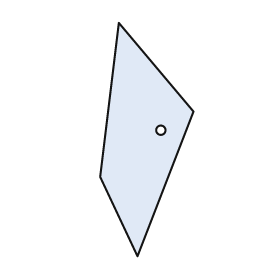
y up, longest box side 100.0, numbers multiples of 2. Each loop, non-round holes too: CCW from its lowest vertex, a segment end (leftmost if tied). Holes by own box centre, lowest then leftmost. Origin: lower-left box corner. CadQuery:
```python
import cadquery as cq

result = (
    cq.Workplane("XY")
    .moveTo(16.0, 0.0)
    .lineTo(40.0, 62.0)
    .lineTo(8.0, 100.0)
    .lineTo(0.0, 34.0)
    .close()
    .moveTo(26.0, 54.0)
    .circle(2.0)
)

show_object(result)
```